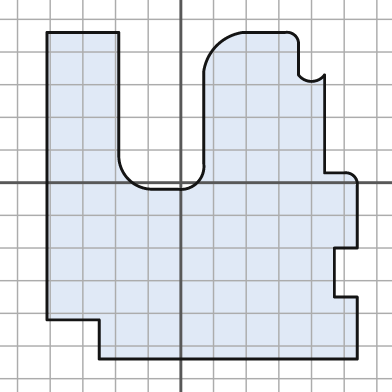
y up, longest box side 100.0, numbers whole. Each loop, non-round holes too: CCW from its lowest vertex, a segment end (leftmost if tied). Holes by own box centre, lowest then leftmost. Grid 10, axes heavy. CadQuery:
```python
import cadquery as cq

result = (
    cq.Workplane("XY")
    .moveTo(-25.0, -54.0)
    .lineTo(54.0, -54.0)
    .lineTo(54.0, -35.0)
    .lineTo(47.0, -35.0)
    .lineTo(47.0, -20.0)
    .lineTo(54.0, -20.0)
    .lineTo(54.0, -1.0)
    .threePointArc((53.0, 2.0), (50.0, 3.0))
    .lineTo(44.0, 3.0)
    .lineTo(44.0, 33.0)
    .threePointArc((40.0, 31.0), (36.0, 33.0))
    .lineTo(36.0, 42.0)
    .threePointArc((35.0, 45.0), (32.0, 46.0))
    .lineTo(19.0, 46.0)
    .threePointArc((11.0, 42.0), (7.0, 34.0))
    .lineTo(7.0, 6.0)
    .threePointArc((5.0, 0.0), (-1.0, -2.0))
    .lineTo(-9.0, -2.0)
    .threePointArc((-16.0, 1.0), (-19.0, 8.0))
    .lineTo(-19.0, 46.0)
    .lineTo(-41.0, 46.0)
    .lineTo(-41.0, -42.0)
    .lineTo(-25.0, -42.0)
    .close()
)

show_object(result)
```